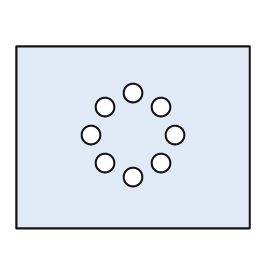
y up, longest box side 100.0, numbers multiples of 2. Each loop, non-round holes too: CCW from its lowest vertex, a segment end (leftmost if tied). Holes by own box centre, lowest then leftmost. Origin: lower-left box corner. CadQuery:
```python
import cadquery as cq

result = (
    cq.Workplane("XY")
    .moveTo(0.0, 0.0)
    .lineTo(100.0, 0.0)
    .lineTo(100.0, 78.0)
    .lineTo(0.0, 78.0)
    .close()
    .moveTo(50.0, 22.0)
    .circle(4.0)
    .moveTo(38.0, 28.0)
    .circle(4.0)
    .moveTo(62.0, 28.0)
    .circle(4.0)
    .moveTo(32.0, 40.0)
    .circle(4.0)
    .moveTo(68.0, 40.0)
    .circle(4.0)
    .moveTo(38.0, 52.0)
    .circle(4.0)
    .moveTo(62.0, 52.0)
    .circle(4.0)
    .moveTo(50.0, 58.0)
    .circle(4.0)
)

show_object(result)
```